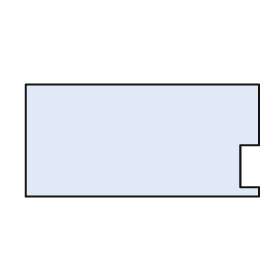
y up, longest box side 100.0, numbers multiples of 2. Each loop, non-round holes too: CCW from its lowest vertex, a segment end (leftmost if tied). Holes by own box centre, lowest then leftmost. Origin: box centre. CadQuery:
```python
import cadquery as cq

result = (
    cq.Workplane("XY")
    .moveTo(-50.0, -24.0)
    .lineTo(50.0, -24.0)
    .lineTo(50.0, -20.0)
    .lineTo(42.0, -20.0)
    .lineTo(42.0, -2.0)
    .lineTo(50.0, -2.0)
    .lineTo(50.0, 24.0)
    .lineTo(-50.0, 24.0)
    .close()
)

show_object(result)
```